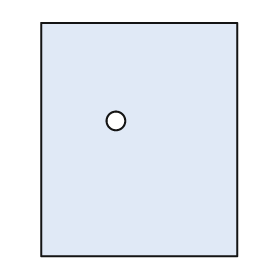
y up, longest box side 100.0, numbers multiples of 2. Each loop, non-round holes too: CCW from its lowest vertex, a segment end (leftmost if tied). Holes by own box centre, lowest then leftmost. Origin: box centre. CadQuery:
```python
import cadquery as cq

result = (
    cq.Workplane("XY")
    .moveTo(-42.0, -50.0)
    .lineTo(42.0, -50.0)
    .lineTo(42.0, 50.0)
    .lineTo(-42.0, 50.0)
    .close()
    .moveTo(-10.0, 8.0)
    .circle(4.0)
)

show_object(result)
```